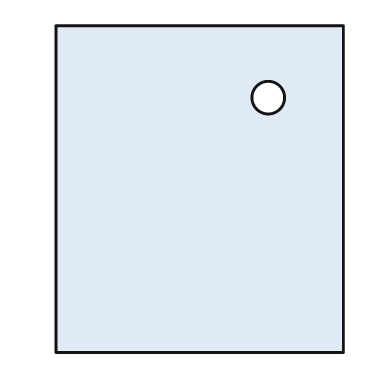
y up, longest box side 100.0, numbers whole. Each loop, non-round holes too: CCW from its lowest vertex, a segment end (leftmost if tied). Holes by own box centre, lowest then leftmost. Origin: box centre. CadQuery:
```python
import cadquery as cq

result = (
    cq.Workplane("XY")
    .moveTo(-44.0, -50.0)
    .lineTo(44.0, -50.0)
    .lineTo(44.0, 50.0)
    .lineTo(-44.0, 50.0)
    .close()
    .moveTo(21.0, 28.0)
    .circle(5.0)
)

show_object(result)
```